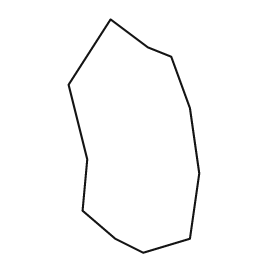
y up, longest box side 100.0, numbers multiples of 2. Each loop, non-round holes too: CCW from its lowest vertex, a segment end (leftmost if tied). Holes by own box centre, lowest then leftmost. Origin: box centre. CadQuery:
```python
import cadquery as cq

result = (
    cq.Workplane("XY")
    .moveTo(4.0, -50.0)
    .lineTo(24.0, -44.0)
    .lineTo(28.0, -16.0)
    .lineTo(24.0, 12.0)
    .lineTo(16.0, 34.0)
    .lineTo(6.0, 38.0)
    .lineTo(-10.0, 50.0)
    .lineTo(-28.0, 22.0)
    .lineTo(-20.0, -10.0)
    .lineTo(-22.0, -32.0)
    .lineTo(-8.0, -44.0)
    .close()
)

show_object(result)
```